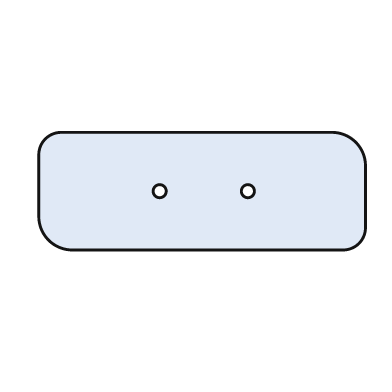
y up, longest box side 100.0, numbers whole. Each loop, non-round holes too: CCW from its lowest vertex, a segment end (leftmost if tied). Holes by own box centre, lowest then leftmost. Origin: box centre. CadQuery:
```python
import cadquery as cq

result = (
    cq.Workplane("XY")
    .moveTo(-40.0, -18.0)
    .lineTo(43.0, -18.0)
    .threePointArc((48.0, -16.0), (50.0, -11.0))
    .lineTo(50.0, 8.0)
    .threePointArc((47.0, 15.0), (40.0, 18.0))
    .lineTo(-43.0, 18.0)
    .threePointArc((-48.0, 16.0), (-50.0, 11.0))
    .lineTo(-50.0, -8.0)
    .threePointArc((-47.0, -15.0), (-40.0, -18.0))
    .close()
    .moveTo(-13.0, 0.0)
    .circle(2.0)
    .moveTo(14.0, 0.0)
    .circle(2.0)
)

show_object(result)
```